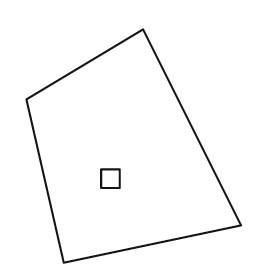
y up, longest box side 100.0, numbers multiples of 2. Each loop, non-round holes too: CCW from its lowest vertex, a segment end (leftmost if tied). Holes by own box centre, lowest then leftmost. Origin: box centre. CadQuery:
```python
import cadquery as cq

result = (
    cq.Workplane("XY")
    .moveTo(-30.0, -50.0)
    .lineTo(46.0, -34.0)
    .lineTo(4.0, 50.0)
    .lineTo(-46.0, 20.0)
    .close()
    .moveTo(-14.0, -18.0)
    .lineTo(-6.0, -18.0)
    .lineTo(-6.0, -10.0)
    .lineTo(-14.0, -10.0)
    .close()
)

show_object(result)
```